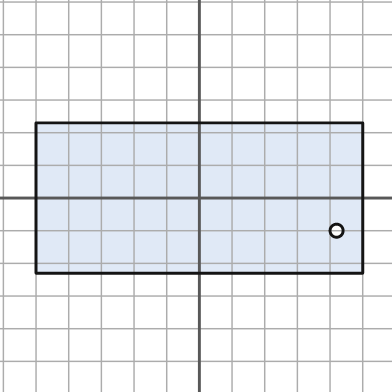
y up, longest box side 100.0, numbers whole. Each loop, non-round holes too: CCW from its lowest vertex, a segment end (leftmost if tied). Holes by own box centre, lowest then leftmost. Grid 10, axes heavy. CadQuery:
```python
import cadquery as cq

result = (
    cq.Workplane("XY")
    .moveTo(-50.0, -23.0)
    .lineTo(50.0, -23.0)
    .lineTo(50.0, 23.0)
    .lineTo(-50.0, 23.0)
    .close()
    .moveTo(42.0, -10.0)
    .circle(2.0)
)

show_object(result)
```